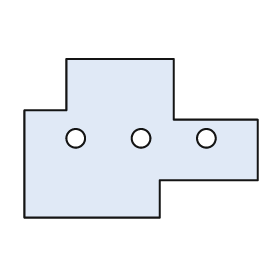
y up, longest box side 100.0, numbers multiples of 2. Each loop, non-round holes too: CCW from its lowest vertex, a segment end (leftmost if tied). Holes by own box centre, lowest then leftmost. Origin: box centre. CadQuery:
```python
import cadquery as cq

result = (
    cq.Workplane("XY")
    .moveTo(-50.0, -34.0)
    .lineTo(8.0, -34.0)
    .lineTo(8.0, -18.0)
    .lineTo(50.0, -18.0)
    .lineTo(50.0, 8.0)
    .lineTo(14.0, 8.0)
    .lineTo(14.0, 34.0)
    .lineTo(-32.0, 34.0)
    .lineTo(-32.0, 12.0)
    .lineTo(-50.0, 12.0)
    .close()
    .moveTo(-28.0, 0.0)
    .circle(4.0)
    .moveTo(0.0, 0.0)
    .circle(4.0)
    .moveTo(28.0, 0.0)
    .circle(4.0)
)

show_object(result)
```